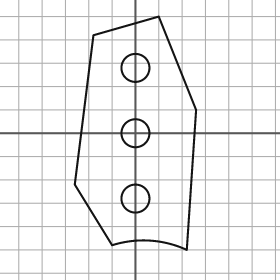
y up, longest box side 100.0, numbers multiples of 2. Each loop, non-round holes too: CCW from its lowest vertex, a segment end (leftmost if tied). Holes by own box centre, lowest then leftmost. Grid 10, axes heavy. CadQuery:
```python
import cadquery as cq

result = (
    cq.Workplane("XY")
    .moveTo(22.0, -50.0)
    .lineTo(26.0, 10.0)
    .lineTo(10.0, 50.0)
    .lineTo(-18.0, 42.0)
    .lineTo(-26.0, -22.0)
    .lineTo(-10.0, -48.0)
    .threePointArc((6.0, -46.0), (22.0, -50.0))
    .close()
    .moveTo(0.0, -28.0)
    .circle(6.0)
    .moveTo(0.0, 0.0)
    .circle(6.0)
    .moveTo(0.0, 28.0)
    .circle(6.0)
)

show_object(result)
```